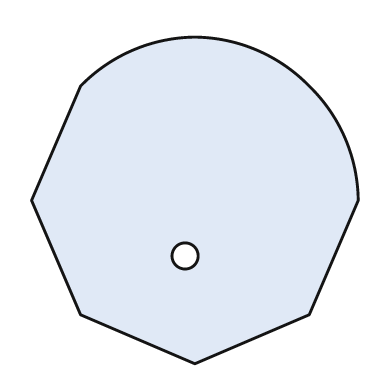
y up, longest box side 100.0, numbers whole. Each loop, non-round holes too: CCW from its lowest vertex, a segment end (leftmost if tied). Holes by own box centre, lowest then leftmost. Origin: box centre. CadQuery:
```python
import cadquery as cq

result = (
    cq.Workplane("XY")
    .moveTo(0.0, -50.0)
    .lineTo(35.0, -35.0)
    .lineTo(50.0, 0.0)
    .threePointArc((46.0, 19.0), (35.0, 35.0))
    .threePointArc((19.0, 46.0), (0.0, 50.0))
    .threePointArc((-19.0, 46.0), (-35.0, 35.0))
    .lineTo(-50.0, 0.0)
    .lineTo(-35.0, -35.0)
    .close()
    .moveTo(-3.0, -17.0)
    .circle(4.0)
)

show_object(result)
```